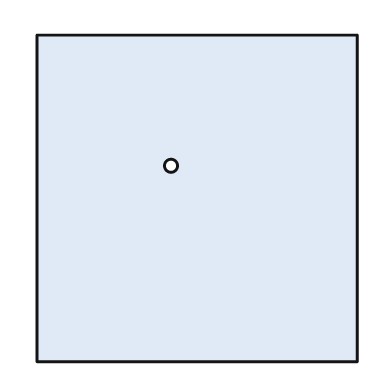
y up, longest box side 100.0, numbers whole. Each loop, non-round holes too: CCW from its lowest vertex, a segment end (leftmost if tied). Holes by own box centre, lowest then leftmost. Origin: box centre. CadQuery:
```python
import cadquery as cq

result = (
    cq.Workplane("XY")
    .moveTo(-49.0, -50.0)
    .lineTo(49.0, -50.0)
    .lineTo(49.0, 50.0)
    .lineTo(-49.0, 50.0)
    .close()
    .moveTo(-8.0, 10.0)
    .circle(2.0)
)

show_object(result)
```